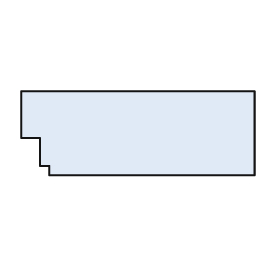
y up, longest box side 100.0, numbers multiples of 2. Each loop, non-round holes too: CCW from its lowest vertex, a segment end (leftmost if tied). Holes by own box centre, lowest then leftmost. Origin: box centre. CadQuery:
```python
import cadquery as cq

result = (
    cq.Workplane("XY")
    .moveTo(-38.0, -18.0)
    .lineTo(50.0, -18.0)
    .lineTo(50.0, 18.0)
    .lineTo(-50.0, 18.0)
    .lineTo(-50.0, -2.0)
    .lineTo(-42.0, -2.0)
    .lineTo(-42.0, -14.0)
    .lineTo(-38.0, -14.0)
    .close()
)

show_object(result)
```